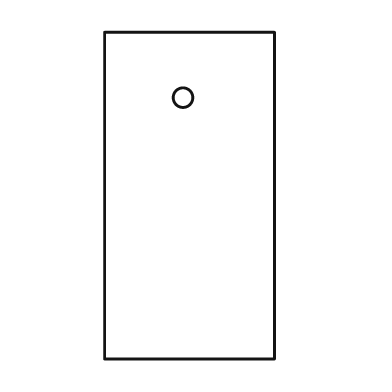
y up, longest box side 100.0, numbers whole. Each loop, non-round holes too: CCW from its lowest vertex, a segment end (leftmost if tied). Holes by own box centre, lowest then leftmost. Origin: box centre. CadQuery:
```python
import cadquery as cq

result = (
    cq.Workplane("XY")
    .moveTo(-26.0, -50.0)
    .lineTo(26.0, -50.0)
    .lineTo(26.0, 50.0)
    .lineTo(-26.0, 50.0)
    .close()
    .moveTo(-2.0, 30.0)
    .circle(3.0)
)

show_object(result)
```